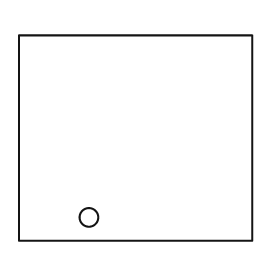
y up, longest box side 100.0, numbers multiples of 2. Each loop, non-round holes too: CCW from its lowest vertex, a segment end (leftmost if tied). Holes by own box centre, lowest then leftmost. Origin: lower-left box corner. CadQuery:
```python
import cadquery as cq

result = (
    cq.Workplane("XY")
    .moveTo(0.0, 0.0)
    .lineTo(100.0, 0.0)
    .lineTo(100.0, 88.0)
    .lineTo(0.0, 88.0)
    .close()
    .moveTo(30.0, 10.0)
    .circle(4.0)
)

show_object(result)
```